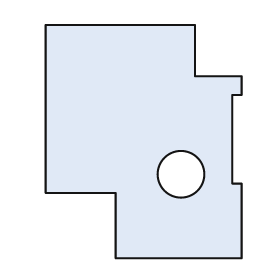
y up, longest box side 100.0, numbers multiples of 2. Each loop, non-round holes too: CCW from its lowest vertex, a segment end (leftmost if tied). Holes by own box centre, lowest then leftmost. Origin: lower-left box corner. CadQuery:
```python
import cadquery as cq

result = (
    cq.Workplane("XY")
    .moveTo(30.0, 0.0)
    .lineTo(84.0, 0.0)
    .lineTo(84.0, 32.0)
    .lineTo(80.0, 32.0)
    .lineTo(80.0, 70.0)
    .lineTo(84.0, 70.0)
    .lineTo(84.0, 78.0)
    .lineTo(64.0, 78.0)
    .lineTo(64.0, 100.0)
    .lineTo(0.0, 100.0)
    .lineTo(0.0, 28.0)
    .lineTo(30.0, 28.0)
    .close()
    .moveTo(58.0, 36.0)
    .circle(10.0)
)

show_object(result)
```